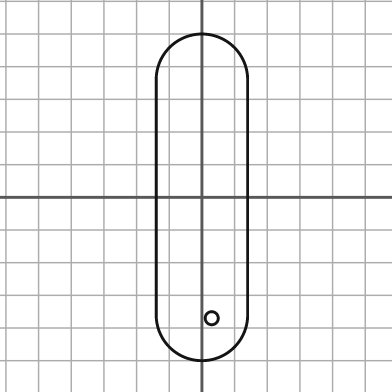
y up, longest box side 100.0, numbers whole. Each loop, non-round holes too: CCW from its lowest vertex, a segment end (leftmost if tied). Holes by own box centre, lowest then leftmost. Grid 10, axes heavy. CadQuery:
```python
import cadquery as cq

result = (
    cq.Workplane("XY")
    .moveTo(-14.0, -36.0)
    .threePointArc((0.0, -50.0), (14.0, -36.0))
    .lineTo(14.0, 36.0)
    .threePointArc((0.0, 50.0), (-14.0, 36.0))
    .close()
    .moveTo(3.0, -37.0)
    .circle(2.0)
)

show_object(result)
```